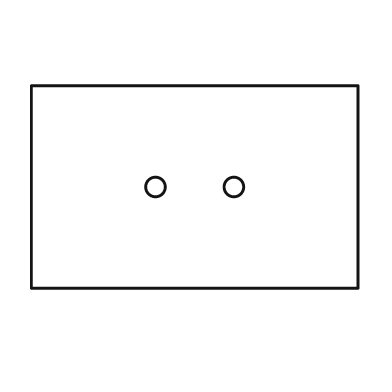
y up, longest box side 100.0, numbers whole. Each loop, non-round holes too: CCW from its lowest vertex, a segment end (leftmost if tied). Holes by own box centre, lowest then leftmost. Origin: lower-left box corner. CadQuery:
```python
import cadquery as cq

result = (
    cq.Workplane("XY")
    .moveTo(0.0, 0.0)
    .lineTo(100.0, 0.0)
    .lineTo(100.0, 62.0)
    .lineTo(0.0, 62.0)
    .close()
    .moveTo(38.0, 31.0)
    .circle(3.0)
    .moveTo(62.0, 31.0)
    .circle(3.0)
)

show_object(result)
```